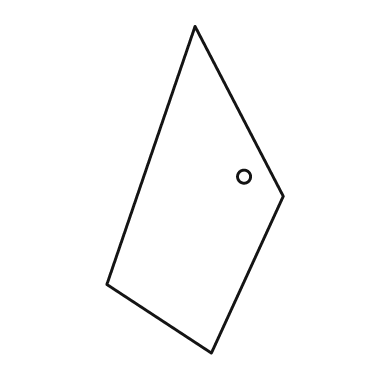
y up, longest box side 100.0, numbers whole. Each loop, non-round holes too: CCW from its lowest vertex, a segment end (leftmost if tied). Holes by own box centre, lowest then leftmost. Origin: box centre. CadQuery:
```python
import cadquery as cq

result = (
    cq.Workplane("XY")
    .moveTo(5.0, -50.0)
    .lineTo(27.0, -2.0)
    .lineTo(0.0, 50.0)
    .lineTo(-27.0, -29.0)
    .close()
    .moveTo(15.0, 4.0)
    .circle(2.0)
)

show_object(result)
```